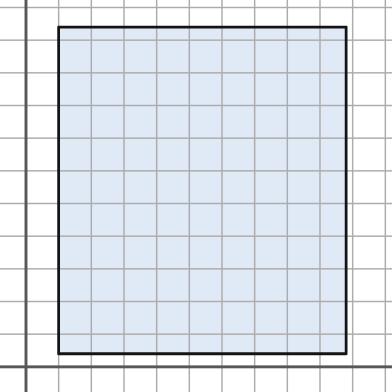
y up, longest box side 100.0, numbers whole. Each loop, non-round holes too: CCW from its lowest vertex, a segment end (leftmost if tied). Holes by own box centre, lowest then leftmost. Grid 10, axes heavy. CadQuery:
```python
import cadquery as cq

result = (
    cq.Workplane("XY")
    .moveTo(10.0, 4.0)
    .lineTo(98.0, 4.0)
    .lineTo(98.0, 104.0)
    .lineTo(10.0, 104.0)
    .close()
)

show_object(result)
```